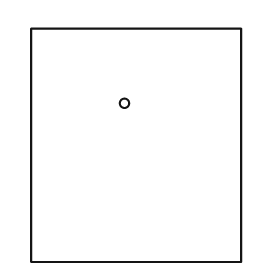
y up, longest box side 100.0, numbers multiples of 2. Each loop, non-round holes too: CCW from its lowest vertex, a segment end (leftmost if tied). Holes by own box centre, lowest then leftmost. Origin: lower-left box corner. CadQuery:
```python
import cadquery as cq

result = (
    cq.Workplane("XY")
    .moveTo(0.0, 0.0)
    .lineTo(90.0, 0.0)
    .lineTo(90.0, 100.0)
    .lineTo(0.0, 100.0)
    .close()
    .moveTo(40.0, 68.0)
    .circle(2.0)
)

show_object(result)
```